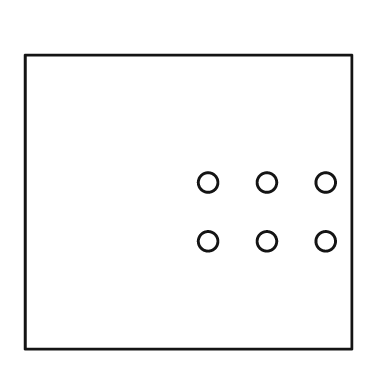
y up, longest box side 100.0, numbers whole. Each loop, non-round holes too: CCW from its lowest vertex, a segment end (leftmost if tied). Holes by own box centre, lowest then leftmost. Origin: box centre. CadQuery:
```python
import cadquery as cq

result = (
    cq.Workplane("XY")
    .moveTo(-50.0, -45.0)
    .lineTo(50.0, -45.0)
    .lineTo(50.0, 45.0)
    .lineTo(-50.0, 45.0)
    .close()
    .moveTo(6.0, -12.0)
    .circle(3.0)
    .moveTo(24.0, -12.0)
    .circle(3.0)
    .moveTo(42.0, -12.0)
    .circle(3.0)
    .moveTo(6.0, 6.0)
    .circle(3.0)
    .moveTo(24.0, 6.0)
    .circle(3.0)
    .moveTo(42.0, 6.0)
    .circle(3.0)
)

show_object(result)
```